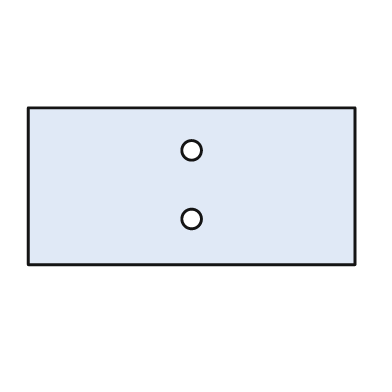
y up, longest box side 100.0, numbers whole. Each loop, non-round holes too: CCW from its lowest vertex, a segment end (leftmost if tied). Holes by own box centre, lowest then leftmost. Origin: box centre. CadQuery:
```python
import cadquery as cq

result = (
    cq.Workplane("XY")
    .moveTo(-50.0, -24.0)
    .lineTo(50.0, -24.0)
    .lineTo(50.0, 24.0)
    .lineTo(-50.0, 24.0)
    .close()
    .moveTo(0.0, -10.0)
    .circle(3.0)
    .moveTo(0.0, 11.0)
    .circle(3.0)
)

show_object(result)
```